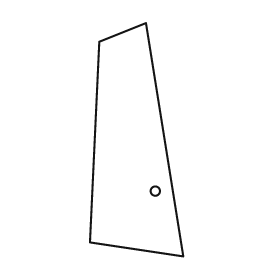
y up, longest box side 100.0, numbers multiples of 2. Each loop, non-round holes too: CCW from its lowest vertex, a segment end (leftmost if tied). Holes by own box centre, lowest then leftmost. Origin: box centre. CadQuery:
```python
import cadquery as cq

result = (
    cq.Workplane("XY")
    .moveTo(20.0, -50.0)
    .lineTo(4.0, 50.0)
    .lineTo(-16.0, 42.0)
    .lineTo(-20.0, -44.0)
    .close()
    .moveTo(8.0, -22.0)
    .circle(2.0)
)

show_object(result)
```